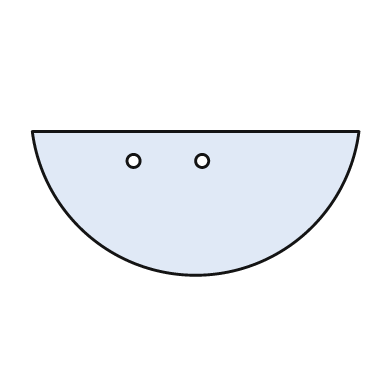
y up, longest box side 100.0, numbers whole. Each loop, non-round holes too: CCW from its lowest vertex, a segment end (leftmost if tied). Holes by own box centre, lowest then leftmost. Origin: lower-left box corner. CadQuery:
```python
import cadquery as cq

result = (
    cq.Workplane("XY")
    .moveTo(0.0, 44.0)
    .threePointArc((50.0, 0.0), (100.0, 44.0))
    .close()
    .moveTo(31.0, 35.0)
    .circle(2.0)
    .moveTo(52.0, 35.0)
    .circle(2.0)
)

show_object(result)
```